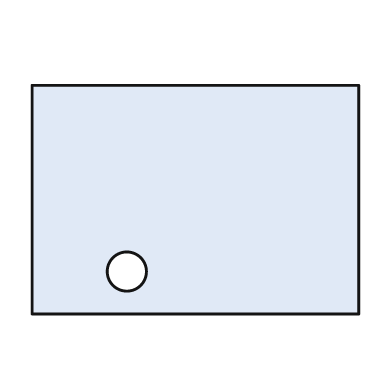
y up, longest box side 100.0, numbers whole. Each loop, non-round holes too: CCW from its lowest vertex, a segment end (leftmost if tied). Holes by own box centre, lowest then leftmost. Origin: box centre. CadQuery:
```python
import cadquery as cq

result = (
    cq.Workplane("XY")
    .moveTo(-50.0, -35.0)
    .lineTo(50.0, -35.0)
    .lineTo(50.0, 35.0)
    .lineTo(-50.0, 35.0)
    .close()
    .moveTo(-21.0, -22.0)
    .circle(6.0)
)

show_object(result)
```